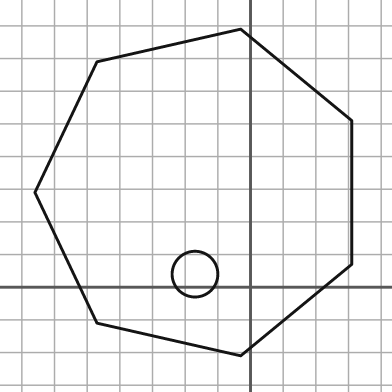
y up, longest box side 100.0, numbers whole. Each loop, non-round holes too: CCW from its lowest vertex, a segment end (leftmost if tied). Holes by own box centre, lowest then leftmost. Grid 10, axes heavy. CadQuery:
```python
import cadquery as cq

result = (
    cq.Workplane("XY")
    .moveTo(-3.0, -21.0)
    .lineTo(31.0, 7.0)
    .lineTo(31.0, 51.0)
    .lineTo(-3.0, 79.0)
    .lineTo(-47.0, 69.0)
    .lineTo(-66.0, 29.0)
    .lineTo(-47.0, -11.0)
    .close()
    .moveTo(-17.0, 4.0)
    .circle(7.0)
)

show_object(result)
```